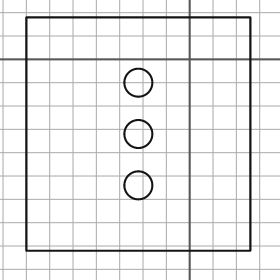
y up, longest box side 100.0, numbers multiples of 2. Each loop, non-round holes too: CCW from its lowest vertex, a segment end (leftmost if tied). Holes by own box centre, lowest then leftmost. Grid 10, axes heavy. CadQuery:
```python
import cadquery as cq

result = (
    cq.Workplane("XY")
    .moveTo(-70.0, -82.0)
    .lineTo(26.0, -82.0)
    .lineTo(26.0, 18.0)
    .lineTo(-70.0, 18.0)
    .close()
    .moveTo(-22.0, -54.0)
    .circle(6.0)
    .moveTo(-22.0, -32.0)
    .circle(6.0)
    .moveTo(-22.0, -10.0)
    .circle(6.0)
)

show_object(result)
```